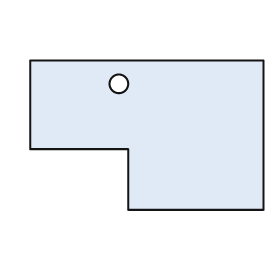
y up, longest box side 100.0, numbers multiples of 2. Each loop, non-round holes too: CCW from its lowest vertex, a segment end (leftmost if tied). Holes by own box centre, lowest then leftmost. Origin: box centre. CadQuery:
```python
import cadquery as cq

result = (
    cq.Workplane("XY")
    .moveTo(-8.0, -32.0)
    .lineTo(50.0, -32.0)
    .lineTo(50.0, 32.0)
    .lineTo(-50.0, 32.0)
    .lineTo(-50.0, -6.0)
    .lineTo(-8.0, -6.0)
    .close()
    .moveTo(-12.0, 22.0)
    .circle(4.0)
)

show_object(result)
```